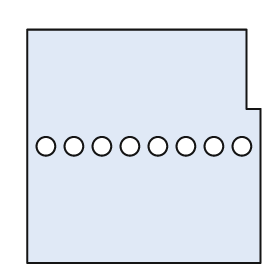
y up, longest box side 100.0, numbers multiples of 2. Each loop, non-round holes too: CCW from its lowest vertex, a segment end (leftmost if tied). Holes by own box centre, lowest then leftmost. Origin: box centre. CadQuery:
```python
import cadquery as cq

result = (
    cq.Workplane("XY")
    .moveTo(-50.0, -50.0)
    .lineTo(50.0, -50.0)
    .lineTo(50.0, 16.0)
    .lineTo(44.0, 16.0)
    .lineTo(44.0, 50.0)
    .lineTo(-50.0, 50.0)
    .close()
    .moveTo(-42.0, 0.0)
    .circle(4.0)
    .moveTo(-30.0, 0.0)
    .circle(4.0)
    .moveTo(-18.0, 0.0)
    .circle(4.0)
    .moveTo(-6.0, 0.0)
    .circle(4.0)
    .moveTo(6.0, 0.0)
    .circle(4.0)
    .moveTo(18.0, 0.0)
    .circle(4.0)
    .moveTo(30.0, 0.0)
    .circle(4.0)
    .moveTo(42.0, 0.0)
    .circle(4.0)
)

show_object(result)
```